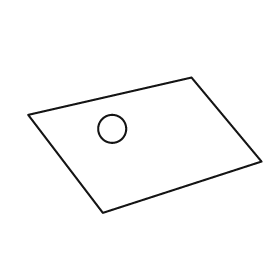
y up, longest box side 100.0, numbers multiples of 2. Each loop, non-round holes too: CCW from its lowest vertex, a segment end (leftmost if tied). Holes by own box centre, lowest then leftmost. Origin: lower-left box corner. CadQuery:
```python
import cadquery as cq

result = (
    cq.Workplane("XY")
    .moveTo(32.0, 0.0)
    .lineTo(100.0, 22.0)
    .lineTo(70.0, 58.0)
    .lineTo(0.0, 42.0)
    .close()
    .moveTo(36.0, 36.0)
    .circle(6.0)
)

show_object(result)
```